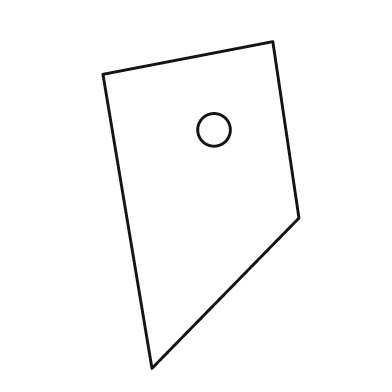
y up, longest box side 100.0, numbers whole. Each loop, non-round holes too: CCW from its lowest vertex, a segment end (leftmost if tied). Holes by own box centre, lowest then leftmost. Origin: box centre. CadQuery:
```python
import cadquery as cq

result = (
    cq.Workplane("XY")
    .moveTo(-15.0, -50.0)
    .lineTo(30.0, -4.0)
    .lineTo(22.0, 50.0)
    .lineTo(-30.0, 40.0)
    .close()
    .moveTo(4.0, 23.0)
    .circle(5.0)
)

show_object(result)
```